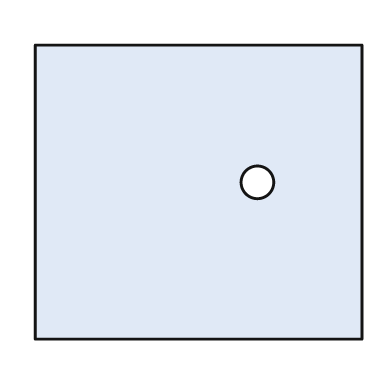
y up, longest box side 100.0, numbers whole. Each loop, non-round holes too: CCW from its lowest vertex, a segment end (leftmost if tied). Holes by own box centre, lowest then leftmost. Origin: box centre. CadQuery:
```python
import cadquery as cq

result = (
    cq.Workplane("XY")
    .moveTo(-50.0, -45.0)
    .lineTo(50.0, -45.0)
    .lineTo(50.0, 45.0)
    .lineTo(-50.0, 45.0)
    .close()
    .moveTo(18.0, 3.0)
    .circle(5.0)
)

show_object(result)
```